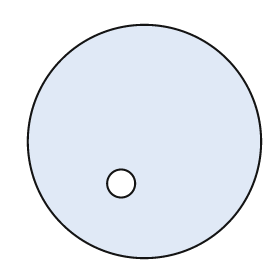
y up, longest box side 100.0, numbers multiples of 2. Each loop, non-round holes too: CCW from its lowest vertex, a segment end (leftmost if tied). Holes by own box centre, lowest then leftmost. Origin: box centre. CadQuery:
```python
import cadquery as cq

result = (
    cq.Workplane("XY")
    .moveTo(0.0, 0.0)
    .circle(50.0)
    .moveTo(-10.0, -18.0)
    .circle(6.0)
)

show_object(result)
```